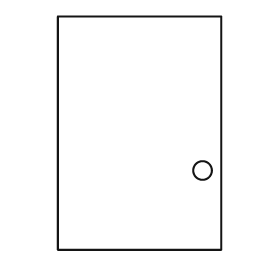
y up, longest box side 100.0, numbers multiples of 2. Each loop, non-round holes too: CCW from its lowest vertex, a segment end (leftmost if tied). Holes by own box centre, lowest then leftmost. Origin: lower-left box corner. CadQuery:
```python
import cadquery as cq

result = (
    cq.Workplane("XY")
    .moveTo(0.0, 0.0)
    .lineTo(70.0, 0.0)
    .lineTo(70.0, 100.0)
    .lineTo(0.0, 100.0)
    .close()
    .moveTo(62.0, 34.0)
    .circle(4.0)
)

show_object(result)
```